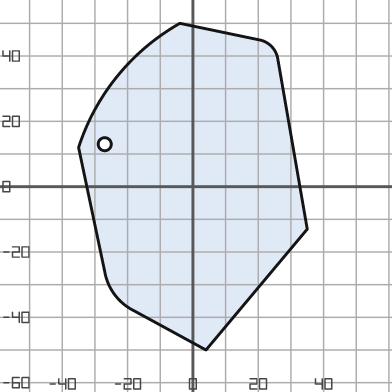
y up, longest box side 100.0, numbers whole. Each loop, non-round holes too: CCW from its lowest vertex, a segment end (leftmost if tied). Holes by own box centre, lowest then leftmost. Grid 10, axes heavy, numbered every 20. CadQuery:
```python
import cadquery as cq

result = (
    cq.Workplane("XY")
    .moveTo(4.0, -50.0)
    .lineTo(35.0, -13.0)
    .lineTo(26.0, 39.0)
    .threePointArc((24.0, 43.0), (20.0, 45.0))
    .lineTo(-4.0, 50.0)
    .threePointArc((-23.0, 34.0), (-35.0, 12.0))
    .lineTo(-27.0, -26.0)
    .threePointArc((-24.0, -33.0), (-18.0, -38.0))
    .close()
    .moveTo(-27.0, 13.0)
    .circle(2.0)
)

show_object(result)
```